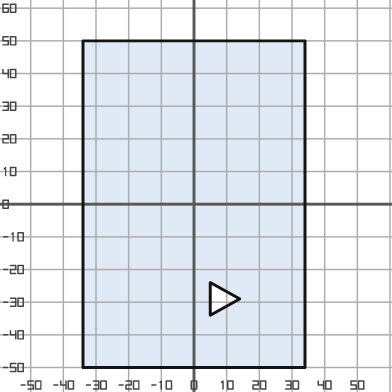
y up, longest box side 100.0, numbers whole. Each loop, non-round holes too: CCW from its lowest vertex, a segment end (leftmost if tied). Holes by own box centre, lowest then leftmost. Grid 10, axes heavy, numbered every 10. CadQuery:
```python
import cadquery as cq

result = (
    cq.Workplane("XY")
    .moveTo(-34.0, -50.0)
    .lineTo(34.0, -50.0)
    .lineTo(34.0, 50.0)
    .lineTo(-34.0, 50.0)
    .close()
    .moveTo(5.0, -34.0)
    .lineTo(14.0, -29.0)
    .lineTo(5.0, -24.0)
    .close()
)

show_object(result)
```